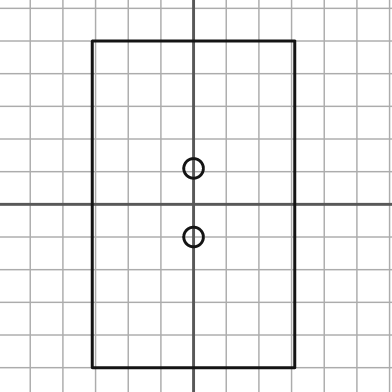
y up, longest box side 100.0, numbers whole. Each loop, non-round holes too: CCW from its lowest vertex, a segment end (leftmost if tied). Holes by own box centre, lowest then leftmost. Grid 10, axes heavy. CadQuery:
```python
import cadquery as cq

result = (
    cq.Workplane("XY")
    .moveTo(-31.0, -50.0)
    .lineTo(31.0, -50.0)
    .lineTo(31.0, 50.0)
    .lineTo(-31.0, 50.0)
    .close()
    .moveTo(0.0, -10.0)
    .circle(3.0)
    .moveTo(0.0, 11.0)
    .circle(3.0)
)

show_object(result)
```